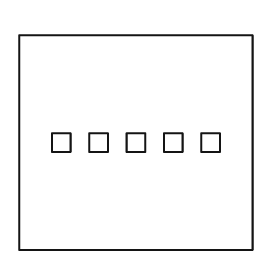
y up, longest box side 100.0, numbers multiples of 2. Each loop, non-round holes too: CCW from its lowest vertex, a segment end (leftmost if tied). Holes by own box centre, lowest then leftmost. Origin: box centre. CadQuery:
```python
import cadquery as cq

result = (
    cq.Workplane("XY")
    .moveTo(-50.0, -46.0)
    .lineTo(50.0, -46.0)
    .lineTo(50.0, 46.0)
    .lineTo(-50.0, 46.0)
    .close()
    .moveTo(-36.0, -4.0)
    .lineTo(-28.0, -4.0)
    .lineTo(-28.0, 4.0)
    .lineTo(-36.0, 4.0)
    .close()
    .moveTo(-20.0, -4.0)
    .lineTo(-12.0, -4.0)
    .lineTo(-12.0, 4.0)
    .lineTo(-20.0, 4.0)
    .close()
    .moveTo(-4.0, -4.0)
    .lineTo(4.0, -4.0)
    .lineTo(4.0, 4.0)
    .lineTo(-4.0, 4.0)
    .close()
    .moveTo(12.0, -4.0)
    .lineTo(20.0, -4.0)
    .lineTo(20.0, 4.0)
    .lineTo(12.0, 4.0)
    .close()
    .moveTo(28.0, -4.0)
    .lineTo(36.0, -4.0)
    .lineTo(36.0, 4.0)
    .lineTo(28.0, 4.0)
    .close()
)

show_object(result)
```